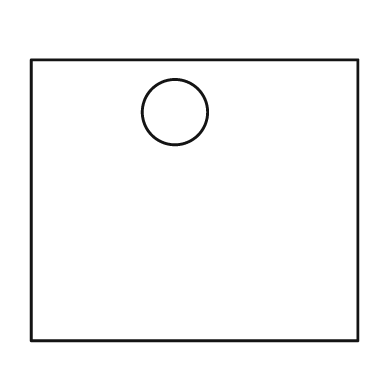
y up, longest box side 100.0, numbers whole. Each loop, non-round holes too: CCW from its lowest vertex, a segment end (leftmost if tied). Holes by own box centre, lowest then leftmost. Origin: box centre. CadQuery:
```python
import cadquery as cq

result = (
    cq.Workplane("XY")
    .moveTo(-50.0, -43.0)
    .lineTo(50.0, -43.0)
    .lineTo(50.0, 43.0)
    .lineTo(-50.0, 43.0)
    .close()
    .moveTo(-6.0, 27.0)
    .circle(10.0)
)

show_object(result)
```